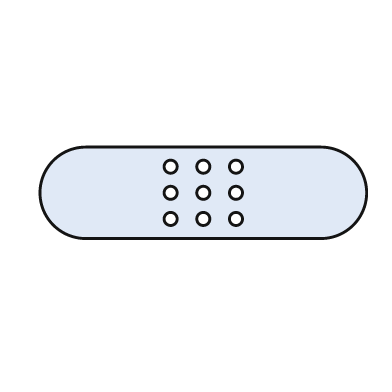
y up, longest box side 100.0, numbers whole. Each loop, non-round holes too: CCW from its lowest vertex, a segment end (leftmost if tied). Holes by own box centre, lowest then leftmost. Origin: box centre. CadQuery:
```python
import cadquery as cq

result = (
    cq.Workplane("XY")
    .moveTo(-36.0, -14.0)
    .lineTo(36.0, -14.0)
    .threePointArc((50.0, 0.0), (36.0, 14.0))
    .lineTo(-36.0, 14.0)
    .threePointArc((-50.0, 0.0), (-36.0, -14.0))
    .close()
    .moveTo(-10.0, -8.0)
    .circle(2.0)
    .moveTo(0.0, -8.0)
    .circle(2.0)
    .moveTo(10.0, -8.0)
    .circle(2.0)
    .moveTo(-10.0, 0.0)
    .circle(2.0)
    .moveTo(0.0, 0.0)
    .circle(2.0)
    .moveTo(10.0, 0.0)
    .circle(2.0)
    .moveTo(-10.0, 8.0)
    .circle(2.0)
    .moveTo(0.0, 8.0)
    .circle(2.0)
    .moveTo(10.0, 8.0)
    .circle(2.0)
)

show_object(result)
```